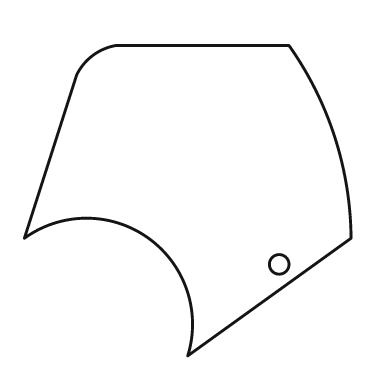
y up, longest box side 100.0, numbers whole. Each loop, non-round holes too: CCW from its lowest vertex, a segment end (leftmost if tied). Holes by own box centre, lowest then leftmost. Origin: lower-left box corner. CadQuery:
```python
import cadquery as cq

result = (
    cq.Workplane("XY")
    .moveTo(50.0, 0.0)
    .lineTo(100.0, 36.0)
    .threePointArc((95.0, 67.0), (81.0, 95.0))
    .lineTo(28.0, 95.0)
    .threePointArc((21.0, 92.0), (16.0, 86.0))
    .lineTo(0.0, 36.0)
    .threePointArc((38.0, 36.0), (50.0, 0.0))
    .close()
    .moveTo(78.0, 28.0)
    .circle(3.0)
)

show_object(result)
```